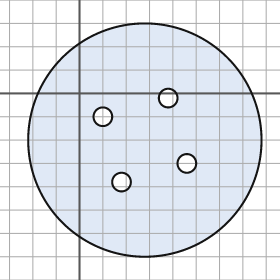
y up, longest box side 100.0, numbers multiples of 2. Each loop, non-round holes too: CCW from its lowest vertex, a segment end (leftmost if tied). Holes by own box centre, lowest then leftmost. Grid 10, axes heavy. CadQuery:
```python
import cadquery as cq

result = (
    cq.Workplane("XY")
    .moveTo(28.0, -20.0)
    .circle(50.0)
    .moveTo(18.0, -38.0)
    .circle(4.0)
    .moveTo(46.0, -30.0)
    .circle(4.0)
    .moveTo(10.0, -10.0)
    .circle(4.0)
    .moveTo(38.0, -2.0)
    .circle(4.0)
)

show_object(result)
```